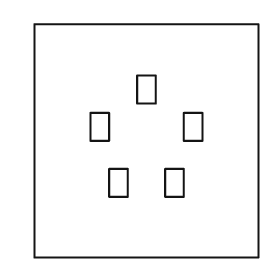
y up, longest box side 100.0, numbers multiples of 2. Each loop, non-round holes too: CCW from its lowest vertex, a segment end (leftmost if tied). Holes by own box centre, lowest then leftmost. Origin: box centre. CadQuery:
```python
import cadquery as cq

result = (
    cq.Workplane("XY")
    .moveTo(-48.0, -50.0)
    .lineTo(48.0, -50.0)
    .lineTo(48.0, 50.0)
    .lineTo(-48.0, 50.0)
    .close()
    .moveTo(-16.0, -24.0)
    .lineTo(-8.0, -24.0)
    .lineTo(-8.0, -12.0)
    .lineTo(-16.0, -12.0)
    .close()
    .moveTo(8.0, -24.0)
    .lineTo(16.0, -24.0)
    .lineTo(16.0, -12.0)
    .lineTo(8.0, -12.0)
    .close()
    .moveTo(-24.0, 0.0)
    .lineTo(-16.0, 0.0)
    .lineTo(-16.0, 12.0)
    .lineTo(-24.0, 12.0)
    .close()
    .moveTo(16.0, 0.0)
    .lineTo(24.0, 0.0)
    .lineTo(24.0, 12.0)
    .lineTo(16.0, 12.0)
    .close()
    .moveTo(-4.0, 16.0)
    .lineTo(4.0, 16.0)
    .lineTo(4.0, 28.0)
    .lineTo(-4.0, 28.0)
    .close()
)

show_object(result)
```